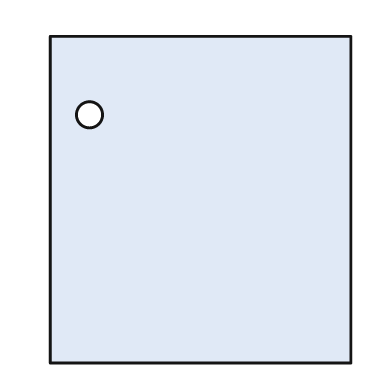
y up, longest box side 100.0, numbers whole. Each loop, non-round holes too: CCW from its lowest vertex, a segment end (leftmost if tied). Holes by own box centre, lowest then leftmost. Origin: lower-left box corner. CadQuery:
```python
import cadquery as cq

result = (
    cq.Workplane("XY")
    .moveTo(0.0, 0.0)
    .lineTo(92.0, 0.0)
    .lineTo(92.0, 100.0)
    .lineTo(0.0, 100.0)
    .close()
    .moveTo(12.0, 76.0)
    .circle(4.0)
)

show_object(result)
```